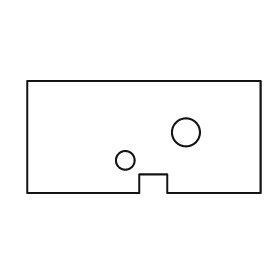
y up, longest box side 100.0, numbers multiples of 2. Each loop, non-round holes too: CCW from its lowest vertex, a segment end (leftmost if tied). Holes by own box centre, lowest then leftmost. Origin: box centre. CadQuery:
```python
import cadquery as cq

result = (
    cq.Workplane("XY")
    .moveTo(-50.0, -24.0)
    .lineTo(-2.0, -24.0)
    .lineTo(-2.0, -16.0)
    .lineTo(10.0, -16.0)
    .lineTo(10.0, -24.0)
    .lineTo(50.0, -24.0)
    .lineTo(50.0, 24.0)
    .lineTo(-50.0, 24.0)
    .close()
    .moveTo(-8.0, -10.0)
    .circle(4.0)
    .moveTo(18.0, 2.0)
    .circle(6.0)
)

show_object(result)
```